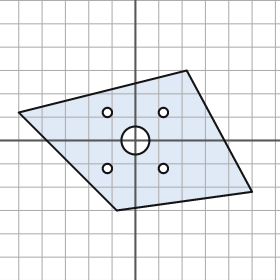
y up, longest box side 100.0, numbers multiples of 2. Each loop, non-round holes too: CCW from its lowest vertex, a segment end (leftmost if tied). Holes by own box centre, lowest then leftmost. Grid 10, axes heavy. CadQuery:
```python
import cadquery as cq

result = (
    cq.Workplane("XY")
    .moveTo(-8.0, -30.0)
    .lineTo(50.0, -22.0)
    .lineTo(22.0, 30.0)
    .lineTo(-50.0, 12.0)
    .close()
    .moveTo(-12.0, -12.0)
    .circle(2.0)
    .moveTo(12.0, -12.0)
    .circle(2.0)
    .moveTo(0.0, 0.0)
    .circle(6.0)
    .moveTo(-12.0, 12.0)
    .circle(2.0)
    .moveTo(12.0, 12.0)
    .circle(2.0)
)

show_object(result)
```